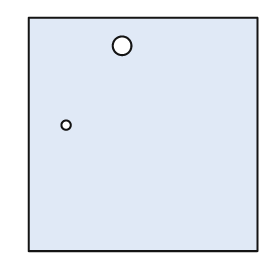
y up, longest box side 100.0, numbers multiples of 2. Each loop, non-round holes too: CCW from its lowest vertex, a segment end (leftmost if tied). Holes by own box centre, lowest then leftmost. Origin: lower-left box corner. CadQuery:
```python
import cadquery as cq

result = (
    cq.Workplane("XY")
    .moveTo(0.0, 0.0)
    .lineTo(98.0, 0.0)
    .lineTo(98.0, 100.0)
    .lineTo(0.0, 100.0)
    .close()
    .moveTo(16.0, 54.0)
    .circle(2.0)
    .moveTo(40.0, 88.0)
    .circle(4.0)
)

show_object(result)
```